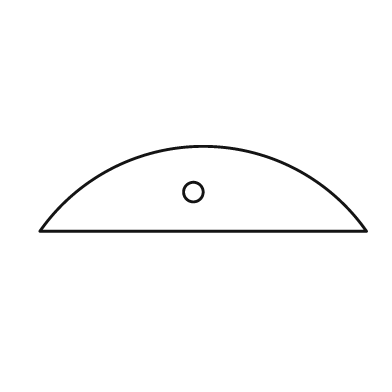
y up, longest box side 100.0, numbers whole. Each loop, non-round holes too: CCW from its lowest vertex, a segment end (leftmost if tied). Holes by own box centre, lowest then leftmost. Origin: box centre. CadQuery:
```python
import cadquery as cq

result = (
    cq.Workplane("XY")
    .moveTo(-50.0, -13.0)
    .lineTo(50.0, -13.0)
    .threePointArc((0.0, 13.0), (-50.0, -13.0))
    .close()
    .moveTo(-3.0, -1.0)
    .circle(3.0)
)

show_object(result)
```